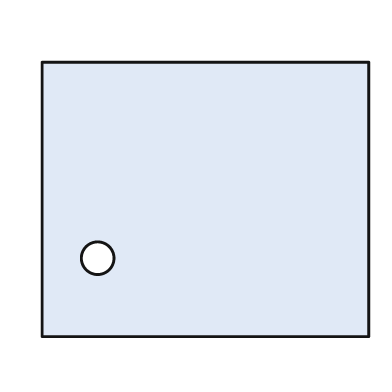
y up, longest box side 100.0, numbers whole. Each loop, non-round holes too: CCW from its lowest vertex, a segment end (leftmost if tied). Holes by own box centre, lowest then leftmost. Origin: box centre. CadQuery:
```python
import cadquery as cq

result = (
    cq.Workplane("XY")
    .moveTo(-50.0, -42.0)
    .lineTo(50.0, -42.0)
    .lineTo(50.0, 42.0)
    .lineTo(-50.0, 42.0)
    .close()
    .moveTo(-33.0, -18.0)
    .circle(5.0)
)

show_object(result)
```